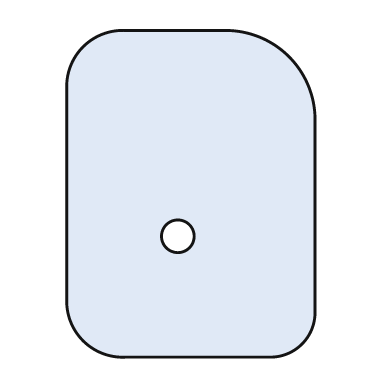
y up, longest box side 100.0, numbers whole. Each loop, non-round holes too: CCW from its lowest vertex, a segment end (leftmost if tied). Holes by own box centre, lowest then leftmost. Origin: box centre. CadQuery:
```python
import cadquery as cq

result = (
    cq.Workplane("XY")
    .moveTo(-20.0, -50.0)
    .lineTo(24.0, -50.0)
    .threePointArc((34.0, -46.0), (38.0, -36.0))
    .lineTo(38.0, 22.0)
    .threePointArc((30.0, 42.0), (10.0, 50.0))
    .lineTo(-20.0, 50.0)
    .threePointArc((-33.0, 45.0), (-38.0, 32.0))
    .lineTo(-38.0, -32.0)
    .threePointArc((-33.0, -45.0), (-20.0, -50.0))
    .close()
    .moveTo(-4.0, -13.0)
    .circle(5.0)
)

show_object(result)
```